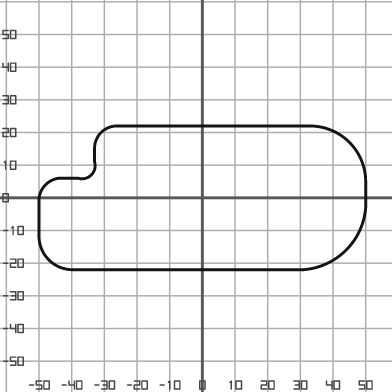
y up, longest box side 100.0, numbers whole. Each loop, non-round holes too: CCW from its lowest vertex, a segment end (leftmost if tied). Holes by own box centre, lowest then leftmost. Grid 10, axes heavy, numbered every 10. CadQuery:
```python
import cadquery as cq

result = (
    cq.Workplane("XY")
    .moveTo(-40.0, -22.0)
    .lineTo(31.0, -22.0)
    .threePointArc((44.0, -16.0), (50.0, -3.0))
    .lineTo(50.0, 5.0)
    .threePointArc((45.0, 17.0), (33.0, 22.0))
    .lineTo(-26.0, 22.0)
    .threePointArc((-31.0, 20.0), (-33.0, 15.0))
    .lineTo(-33.0, 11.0)
    .threePointArc((-34.0, 7.0), (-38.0, 6.0))
    .lineTo(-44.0, 6.0)
    .threePointArc((-48.0, 4.0), (-50.0, 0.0))
    .lineTo(-50.0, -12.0)
    .threePointArc((-47.0, -19.0), (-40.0, -22.0))
    .close()
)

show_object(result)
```